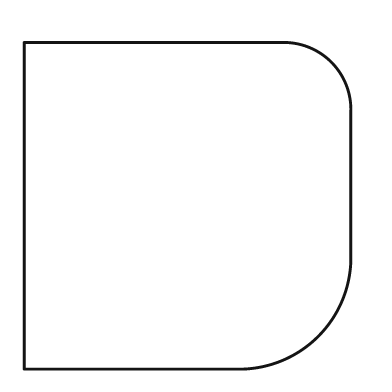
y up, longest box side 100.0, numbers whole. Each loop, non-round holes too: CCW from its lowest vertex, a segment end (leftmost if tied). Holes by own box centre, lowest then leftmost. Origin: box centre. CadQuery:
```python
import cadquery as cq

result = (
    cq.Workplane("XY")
    .moveTo(-50.0, -50.0)
    .lineTo(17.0, -50.0)
    .threePointArc((40.0, -40.0), (50.0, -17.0))
    .lineTo(50.0, 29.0)
    .threePointArc((44.0, 44.0), (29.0, 50.0))
    .lineTo(-50.0, 50.0)
    .close()
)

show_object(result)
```